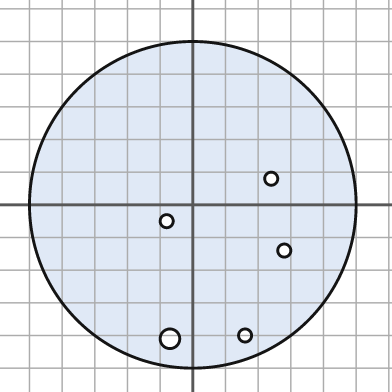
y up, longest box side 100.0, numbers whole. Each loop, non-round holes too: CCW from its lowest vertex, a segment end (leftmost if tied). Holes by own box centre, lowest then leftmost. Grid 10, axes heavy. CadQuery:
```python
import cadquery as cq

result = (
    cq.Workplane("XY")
    .moveTo(0.0, 0.0)
    .circle(50.0)
    .moveTo(-7.0, -41.0)
    .circle(3.0)
    .moveTo(16.0, -40.0)
    .circle(2.0)
    .moveTo(28.0, -14.0)
    .circle(2.0)
    .moveTo(-8.0, -5.0)
    .circle(2.0)
    .moveTo(24.0, 8.0)
    .circle(2.0)
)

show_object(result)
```